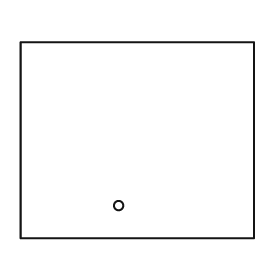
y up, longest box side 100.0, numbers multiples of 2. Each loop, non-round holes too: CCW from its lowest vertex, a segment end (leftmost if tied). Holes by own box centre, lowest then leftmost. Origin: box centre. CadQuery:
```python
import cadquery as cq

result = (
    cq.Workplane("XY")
    .moveTo(-50.0, -42.0)
    .lineTo(50.0, -42.0)
    .lineTo(50.0, 42.0)
    .lineTo(-50.0, 42.0)
    .close()
    .moveTo(-8.0, -28.0)
    .circle(2.0)
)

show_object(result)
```